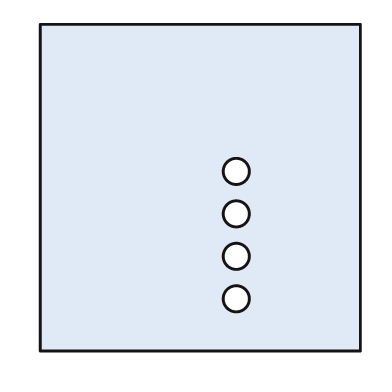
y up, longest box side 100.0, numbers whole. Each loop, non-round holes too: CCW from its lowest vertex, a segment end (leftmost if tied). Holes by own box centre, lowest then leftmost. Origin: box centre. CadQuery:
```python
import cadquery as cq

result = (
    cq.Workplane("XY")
    .moveTo(-49.0, -50.0)
    .lineTo(49.0, -50.0)
    .lineTo(49.0, 50.0)
    .lineTo(-49.0, 50.0)
    .close()
    .moveTo(11.0, -34.0)
    .circle(4.0)
    .moveTo(11.0, -21.0)
    .circle(4.0)
    .moveTo(11.0, -8.0)
    .circle(4.0)
    .moveTo(11.0, 5.0)
    .circle(4.0)
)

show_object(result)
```